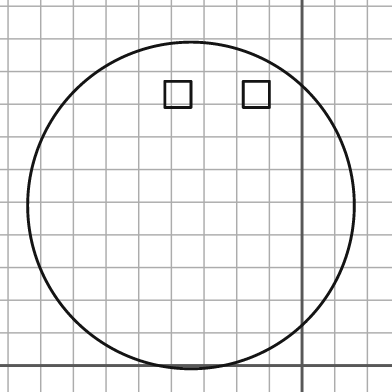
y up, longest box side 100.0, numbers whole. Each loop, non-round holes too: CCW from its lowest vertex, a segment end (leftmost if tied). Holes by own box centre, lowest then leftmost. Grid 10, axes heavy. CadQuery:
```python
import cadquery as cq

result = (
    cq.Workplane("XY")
    .moveTo(-34.0, 49.0)
    .circle(50.0)
    .moveTo(-42.0, 79.0)
    .lineTo(-34.0, 79.0)
    .lineTo(-34.0, 87.0)
    .lineTo(-42.0, 87.0)
    .close()
    .moveTo(-18.0, 79.0)
    .lineTo(-10.0, 79.0)
    .lineTo(-10.0, 87.0)
    .lineTo(-18.0, 87.0)
    .close()
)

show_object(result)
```